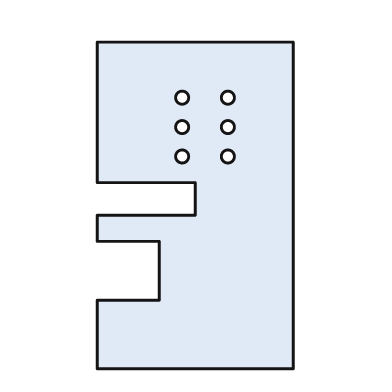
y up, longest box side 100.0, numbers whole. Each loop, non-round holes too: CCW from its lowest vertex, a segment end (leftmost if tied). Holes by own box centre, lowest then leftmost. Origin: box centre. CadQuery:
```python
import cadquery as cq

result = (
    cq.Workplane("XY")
    .moveTo(-30.0, -50.0)
    .lineTo(30.0, -50.0)
    .lineTo(30.0, 50.0)
    .lineTo(-30.0, 50.0)
    .lineTo(-30.0, 7.0)
    .lineTo(0.0, 7.0)
    .lineTo(0.0, -3.0)
    .lineTo(-30.0, -3.0)
    .lineTo(-30.0, -11.0)
    .lineTo(-11.0, -11.0)
    .lineTo(-11.0, -29.0)
    .lineTo(-30.0, -29.0)
    .close()
    .moveTo(-4.0, 15.0)
    .circle(2.0)
    .moveTo(10.0, 15.0)
    .circle(2.0)
    .moveTo(-4.0, 24.0)
    .circle(2.0)
    .moveTo(10.0, 24.0)
    .circle(2.0)
    .moveTo(-4.0, 33.0)
    .circle(2.0)
    .moveTo(10.0, 33.0)
    .circle(2.0)
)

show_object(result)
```